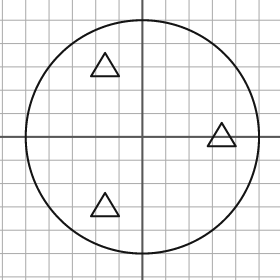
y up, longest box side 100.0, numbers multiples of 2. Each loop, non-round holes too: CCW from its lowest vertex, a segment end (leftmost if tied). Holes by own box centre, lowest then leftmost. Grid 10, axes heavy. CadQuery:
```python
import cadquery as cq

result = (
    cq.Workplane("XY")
    .moveTo(0.0, 0.0)
    .circle(50.0)
    .moveTo(-22.0, -34.0)
    .lineTo(-10.0, -34.0)
    .lineTo(-16.0, -24.0)
    .close()
    .moveTo(28.0, -4.0)
    .lineTo(40.0, -4.0)
    .lineTo(34.0, 6.0)
    .close()
    .moveTo(-22.0, 26.0)
    .lineTo(-10.0, 26.0)
    .lineTo(-16.0, 36.0)
    .close()
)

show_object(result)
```